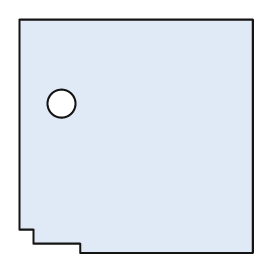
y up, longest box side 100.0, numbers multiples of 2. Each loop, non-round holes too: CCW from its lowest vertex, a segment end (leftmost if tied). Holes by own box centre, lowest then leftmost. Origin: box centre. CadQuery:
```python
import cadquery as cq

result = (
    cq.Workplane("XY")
    .moveTo(-24.0, -50.0)
    .lineTo(50.0, -50.0)
    .lineTo(50.0, 50.0)
    .lineTo(-50.0, 50.0)
    .lineTo(-50.0, -40.0)
    .lineTo(-44.0, -40.0)
    .lineTo(-44.0, -46.0)
    .lineTo(-24.0, -46.0)
    .close()
    .moveTo(-32.0, 14.0)
    .circle(6.0)
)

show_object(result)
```